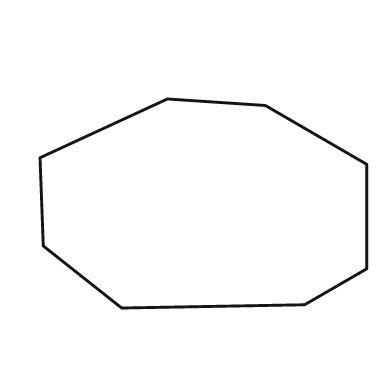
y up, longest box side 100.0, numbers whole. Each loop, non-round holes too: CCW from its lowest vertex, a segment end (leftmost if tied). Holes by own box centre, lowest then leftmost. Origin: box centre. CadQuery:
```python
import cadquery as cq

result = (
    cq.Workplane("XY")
    .moveTo(-25.0, -32.0)
    .lineTo(31.0, -31.0)
    .lineTo(50.0, -20.0)
    .lineTo(50.0, 12.0)
    .lineTo(19.0, 30.0)
    .lineTo(-11.0, 32.0)
    .lineTo(-50.0, 14.0)
    .lineTo(-49.0, -13.0)
    .close()
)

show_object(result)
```